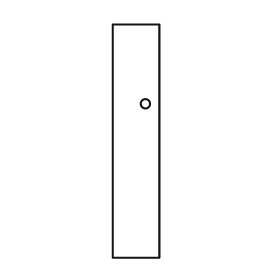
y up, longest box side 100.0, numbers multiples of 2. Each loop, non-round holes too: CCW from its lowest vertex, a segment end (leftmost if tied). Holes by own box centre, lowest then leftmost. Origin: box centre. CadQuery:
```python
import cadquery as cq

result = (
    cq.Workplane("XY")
    .moveTo(-10.0, -50.0)
    .lineTo(10.0, -50.0)
    .lineTo(10.0, 50.0)
    .lineTo(-10.0, 50.0)
    .close()
    .moveTo(4.0, 16.0)
    .circle(2.0)
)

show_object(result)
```